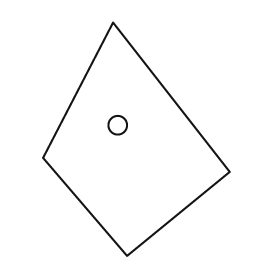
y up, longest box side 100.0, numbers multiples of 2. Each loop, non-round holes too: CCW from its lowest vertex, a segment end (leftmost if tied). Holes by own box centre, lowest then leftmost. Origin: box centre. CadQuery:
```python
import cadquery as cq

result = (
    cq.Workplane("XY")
    .moveTo(-4.0, -50.0)
    .lineTo(40.0, -14.0)
    .lineTo(-10.0, 50.0)
    .lineTo(-40.0, -8.0)
    .close()
    .moveTo(-8.0, 6.0)
    .circle(4.0)
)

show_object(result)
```